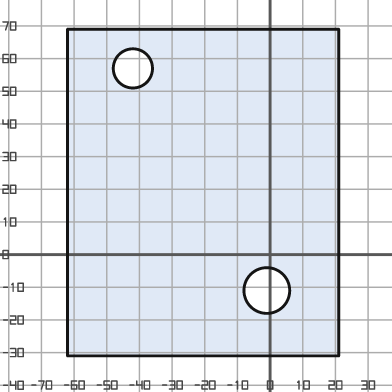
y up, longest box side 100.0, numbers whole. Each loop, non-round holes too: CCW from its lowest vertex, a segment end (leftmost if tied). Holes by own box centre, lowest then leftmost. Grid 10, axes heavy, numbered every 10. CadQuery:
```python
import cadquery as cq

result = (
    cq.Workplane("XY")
    .moveTo(-62.0, -31.0)
    .lineTo(21.0, -31.0)
    .lineTo(21.0, 69.0)
    .lineTo(-62.0, 69.0)
    .close()
    .moveTo(-1.0, -11.0)
    .circle(7.0)
    .moveTo(-42.0, 57.0)
    .circle(6.0)
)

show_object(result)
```